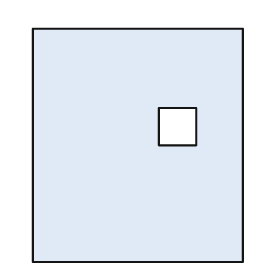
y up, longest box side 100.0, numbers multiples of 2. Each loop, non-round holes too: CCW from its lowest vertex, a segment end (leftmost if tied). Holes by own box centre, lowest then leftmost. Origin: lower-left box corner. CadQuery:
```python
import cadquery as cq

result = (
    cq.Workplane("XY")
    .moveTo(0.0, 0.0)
    .lineTo(90.0, 0.0)
    .lineTo(90.0, 100.0)
    .lineTo(0.0, 100.0)
    .close()
    .moveTo(54.0, 50.0)
    .lineTo(70.0, 50.0)
    .lineTo(70.0, 66.0)
    .lineTo(54.0, 66.0)
    .close()
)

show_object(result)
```